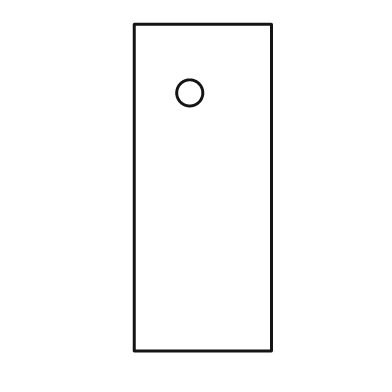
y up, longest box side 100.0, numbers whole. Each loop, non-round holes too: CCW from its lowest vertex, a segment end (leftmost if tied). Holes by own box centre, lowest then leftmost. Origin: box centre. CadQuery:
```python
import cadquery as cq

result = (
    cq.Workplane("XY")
    .moveTo(-21.0, -50.0)
    .lineTo(21.0, -50.0)
    .lineTo(21.0, 50.0)
    .lineTo(-21.0, 50.0)
    .close()
    .moveTo(-4.0, 29.0)
    .circle(4.0)
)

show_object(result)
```